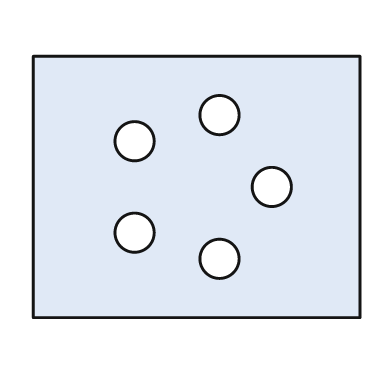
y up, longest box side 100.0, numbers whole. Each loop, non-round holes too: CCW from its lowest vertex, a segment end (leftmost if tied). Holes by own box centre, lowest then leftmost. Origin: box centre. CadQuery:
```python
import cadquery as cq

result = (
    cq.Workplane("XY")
    .moveTo(-50.0, -40.0)
    .lineTo(50.0, -40.0)
    .lineTo(50.0, 40.0)
    .lineTo(-50.0, 40.0)
    .close()
    .moveTo(7.0, -22.0)
    .circle(6.0)
    .moveTo(-19.0, -14.0)
    .circle(6.0)
    .moveTo(23.0, 0.0)
    .circle(6.0)
    .moveTo(-19.0, 14.0)
    .circle(6.0)
    .moveTo(7.0, 22.0)
    .circle(6.0)
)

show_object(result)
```